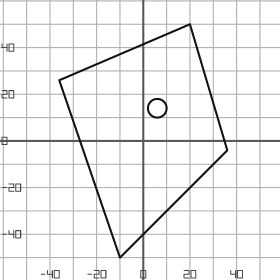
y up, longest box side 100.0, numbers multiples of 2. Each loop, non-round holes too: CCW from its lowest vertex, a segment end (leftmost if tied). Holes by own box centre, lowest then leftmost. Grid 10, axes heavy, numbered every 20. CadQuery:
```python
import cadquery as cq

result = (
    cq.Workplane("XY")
    .moveTo(-10.0, -50.0)
    .lineTo(36.0, -4.0)
    .lineTo(20.0, 50.0)
    .lineTo(-36.0, 26.0)
    .close()
    .moveTo(6.0, 14.0)
    .circle(4.0)
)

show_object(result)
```